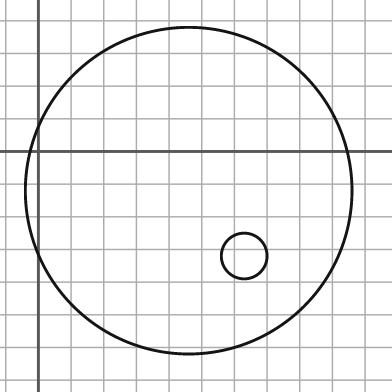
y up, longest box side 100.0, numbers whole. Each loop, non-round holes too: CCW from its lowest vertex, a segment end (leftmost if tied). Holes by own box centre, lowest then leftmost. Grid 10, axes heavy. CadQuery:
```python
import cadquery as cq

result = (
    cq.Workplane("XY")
    .moveTo(46.0, -12.0)
    .circle(50.0)
    .moveTo(63.0, -32.0)
    .circle(7.0)
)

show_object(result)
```